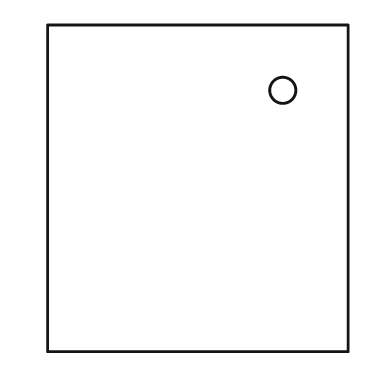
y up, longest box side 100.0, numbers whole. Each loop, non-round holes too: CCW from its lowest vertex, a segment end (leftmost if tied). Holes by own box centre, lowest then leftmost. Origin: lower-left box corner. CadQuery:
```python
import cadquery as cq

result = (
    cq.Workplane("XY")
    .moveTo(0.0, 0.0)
    .lineTo(92.0, 0.0)
    .lineTo(92.0, 100.0)
    .lineTo(0.0, 100.0)
    .close()
    .moveTo(72.0, 80.0)
    .circle(4.0)
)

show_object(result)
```